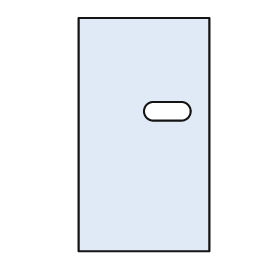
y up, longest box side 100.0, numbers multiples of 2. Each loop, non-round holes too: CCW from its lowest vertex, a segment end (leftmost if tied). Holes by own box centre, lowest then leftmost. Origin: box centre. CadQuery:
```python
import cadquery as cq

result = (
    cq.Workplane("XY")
    .moveTo(-28.0, -50.0)
    .lineTo(28.0, -50.0)
    .lineTo(28.0, 50.0)
    .lineTo(-28.0, 50.0)
    .close()
    .moveTo(4.0, 6.0)
    .lineTo(16.0, 6.0)
    .threePointArc((20.0, 10.0), (16.0, 14.0))
    .lineTo(4.0, 14.0)
    .threePointArc((0.0, 10.0), (4.0, 6.0))
    .close()
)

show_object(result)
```